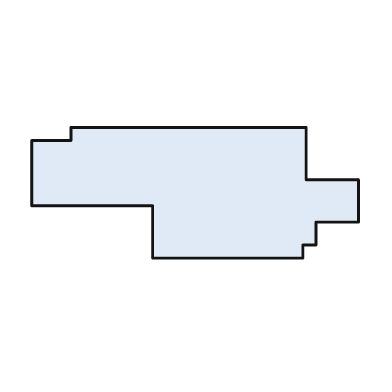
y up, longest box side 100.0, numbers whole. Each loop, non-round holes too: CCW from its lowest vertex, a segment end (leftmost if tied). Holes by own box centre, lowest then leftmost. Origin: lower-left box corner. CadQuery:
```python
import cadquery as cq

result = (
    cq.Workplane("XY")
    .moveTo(37.0, 0.0)
    .lineTo(83.0, 0.0)
    .lineTo(83.0, 4.0)
    .lineTo(87.0, 4.0)
    .lineTo(87.0, 11.0)
    .lineTo(100.0, 11.0)
    .lineTo(100.0, 24.0)
    .lineTo(84.0, 24.0)
    .lineTo(84.0, 40.0)
    .lineTo(12.0, 40.0)
    .lineTo(12.0, 36.0)
    .lineTo(0.0, 36.0)
    .lineTo(0.0, 16.0)
    .lineTo(37.0, 16.0)
    .close()
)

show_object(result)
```